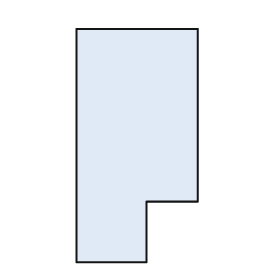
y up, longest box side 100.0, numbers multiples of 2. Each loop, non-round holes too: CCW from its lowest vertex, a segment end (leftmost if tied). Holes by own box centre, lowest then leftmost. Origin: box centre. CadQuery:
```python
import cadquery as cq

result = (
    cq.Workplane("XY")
    .moveTo(-26.0, -50.0)
    .lineTo(4.0, -50.0)
    .lineTo(4.0, -24.0)
    .lineTo(26.0, -24.0)
    .lineTo(26.0, 50.0)
    .lineTo(-26.0, 50.0)
    .close()
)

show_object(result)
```